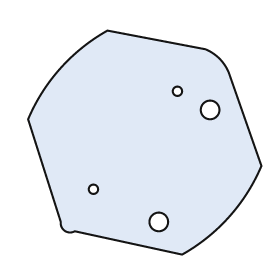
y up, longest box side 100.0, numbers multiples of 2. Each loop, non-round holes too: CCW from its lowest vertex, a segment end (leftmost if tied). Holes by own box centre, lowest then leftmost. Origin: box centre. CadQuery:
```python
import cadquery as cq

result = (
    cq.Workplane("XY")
    .moveTo(16.0, -48.0)
    .threePointArc((36.0, -32.0), (50.0, -10.0))
    .lineTo(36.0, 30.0)
    .threePointArc((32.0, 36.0), (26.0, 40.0))
    .lineTo(-16.0, 48.0)
    .threePointArc((-36.0, 32.0), (-50.0, 10.0))
    .lineTo(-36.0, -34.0)
    .threePointArc((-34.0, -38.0), (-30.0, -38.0))
    .close()
    .moveTo(6.0, -34.0)
    .circle(4.0)
    .moveTo(-22.0, -20.0)
    .circle(2.0)
    .moveTo(28.0, 14.0)
    .circle(4.0)
    .moveTo(14.0, 22.0)
    .circle(2.0)
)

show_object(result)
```